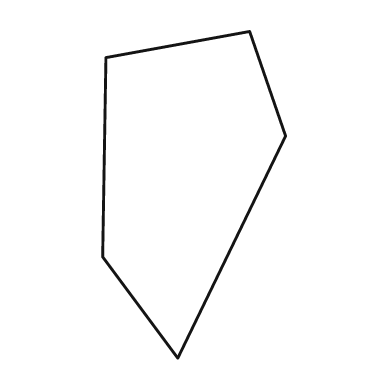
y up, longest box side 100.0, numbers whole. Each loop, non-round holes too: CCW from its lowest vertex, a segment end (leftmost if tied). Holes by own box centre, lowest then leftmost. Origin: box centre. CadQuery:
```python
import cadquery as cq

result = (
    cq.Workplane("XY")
    .moveTo(-5.0, -50.0)
    .lineTo(28.0, 18.0)
    .lineTo(17.0, 50.0)
    .lineTo(-27.0, 42.0)
    .lineTo(-28.0, -19.0)
    .close()
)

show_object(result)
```